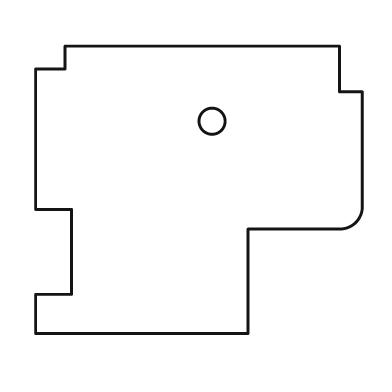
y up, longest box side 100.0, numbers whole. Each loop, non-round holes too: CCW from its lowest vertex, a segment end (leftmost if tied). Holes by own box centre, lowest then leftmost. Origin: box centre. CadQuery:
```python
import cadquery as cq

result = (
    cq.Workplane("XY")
    .moveTo(-50.0, -44.0)
    .lineTo(15.0, -44.0)
    .lineTo(15.0, -12.0)
    .lineTo(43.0, -12.0)
    .threePointArc((48.0, -10.0), (50.0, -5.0))
    .lineTo(50.0, 30.0)
    .lineTo(43.0, 30.0)
    .lineTo(43.0, 44.0)
    .lineTo(-41.0, 44.0)
    .lineTo(-41.0, 37.0)
    .lineTo(-50.0, 37.0)
    .lineTo(-50.0, -6.0)
    .lineTo(-39.0, -6.0)
    .lineTo(-39.0, -32.0)
    .lineTo(-50.0, -32.0)
    .close()
    .moveTo(4.0, 21.0)
    .circle(4.0)
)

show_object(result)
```